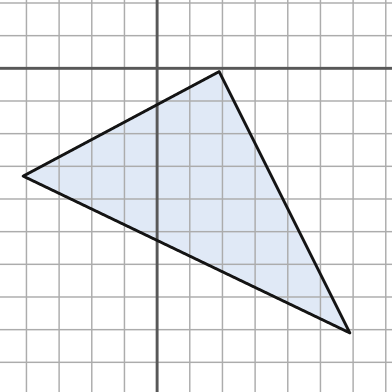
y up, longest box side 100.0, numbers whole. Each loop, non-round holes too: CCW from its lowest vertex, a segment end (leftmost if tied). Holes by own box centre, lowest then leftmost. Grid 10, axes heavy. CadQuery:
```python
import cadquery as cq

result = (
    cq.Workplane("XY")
    .moveTo(59.0, -81.0)
    .lineTo(19.0, -1.0)
    .lineTo(-41.0, -33.0)
    .close()
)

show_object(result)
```